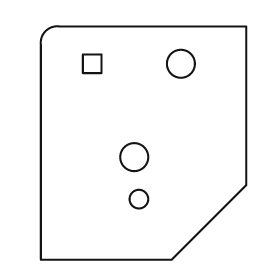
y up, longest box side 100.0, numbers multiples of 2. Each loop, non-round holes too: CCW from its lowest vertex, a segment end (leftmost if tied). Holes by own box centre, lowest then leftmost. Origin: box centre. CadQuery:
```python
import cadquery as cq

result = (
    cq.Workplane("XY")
    .moveTo(-44.0, -50.0)
    .lineTo(12.0, -50.0)
    .lineTo(44.0, -18.0)
    .lineTo(44.0, 50.0)
    .lineTo(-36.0, 50.0)
    .threePointArc((-42.0, 48.0), (-44.0, 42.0))
    .close()
    .moveTo(-2.0, -24.0)
    .circle(4.0)
    .moveTo(-4.0, -6.0)
    .circle(6.0)
    .moveTo(-26.0, 30.0)
    .lineTo(-18.0, 30.0)
    .lineTo(-18.0, 38.0)
    .lineTo(-26.0, 38.0)
    .close()
    .moveTo(16.0, 34.0)
    .circle(6.0)
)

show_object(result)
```